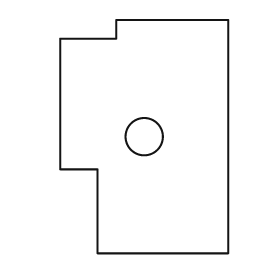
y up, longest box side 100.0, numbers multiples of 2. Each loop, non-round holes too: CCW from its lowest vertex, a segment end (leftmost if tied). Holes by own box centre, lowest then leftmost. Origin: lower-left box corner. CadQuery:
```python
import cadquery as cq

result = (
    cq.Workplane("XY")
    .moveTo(16.0, 0.0)
    .lineTo(72.0, 0.0)
    .lineTo(72.0, 100.0)
    .lineTo(24.0, 100.0)
    .lineTo(24.0, 92.0)
    .lineTo(0.0, 92.0)
    .lineTo(0.0, 36.0)
    .lineTo(16.0, 36.0)
    .close()
    .moveTo(36.0, 50.0)
    .circle(8.0)
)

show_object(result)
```